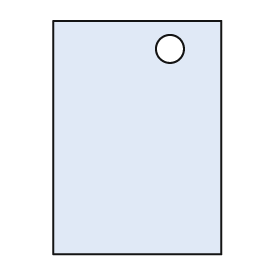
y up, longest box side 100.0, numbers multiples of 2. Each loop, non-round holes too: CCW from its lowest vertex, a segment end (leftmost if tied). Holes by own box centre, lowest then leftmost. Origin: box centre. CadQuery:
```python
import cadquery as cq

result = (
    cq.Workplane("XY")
    .moveTo(-36.0, -50.0)
    .lineTo(36.0, -50.0)
    .lineTo(36.0, 50.0)
    .lineTo(-36.0, 50.0)
    .close()
    .moveTo(14.0, 38.0)
    .circle(6.0)
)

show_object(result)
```